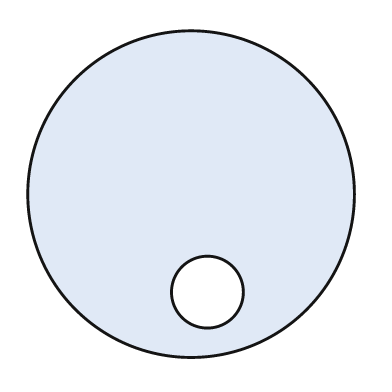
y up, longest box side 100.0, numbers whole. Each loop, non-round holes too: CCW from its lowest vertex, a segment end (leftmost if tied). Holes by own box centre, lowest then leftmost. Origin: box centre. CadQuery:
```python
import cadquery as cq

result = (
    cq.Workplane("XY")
    .moveTo(0.0, 0.0)
    .circle(50.0)
    .moveTo(5.0, -30.0)
    .circle(11.0)
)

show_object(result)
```